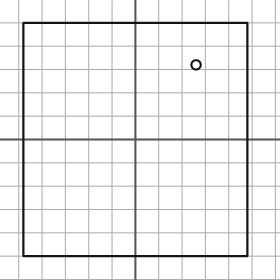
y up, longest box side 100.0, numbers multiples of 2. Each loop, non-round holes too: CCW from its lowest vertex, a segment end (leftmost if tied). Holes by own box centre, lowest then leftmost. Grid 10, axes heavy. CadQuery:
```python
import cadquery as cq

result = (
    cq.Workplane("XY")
    .moveTo(-48.0, -50.0)
    .lineTo(48.0, -50.0)
    .lineTo(48.0, 50.0)
    .lineTo(-48.0, 50.0)
    .close()
    .moveTo(26.0, 32.0)
    .circle(2.0)
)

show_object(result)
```